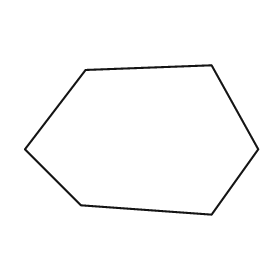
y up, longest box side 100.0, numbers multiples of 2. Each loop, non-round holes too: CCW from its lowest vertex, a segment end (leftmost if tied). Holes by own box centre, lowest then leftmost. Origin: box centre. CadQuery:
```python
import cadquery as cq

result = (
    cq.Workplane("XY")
    .moveTo(30.0, -32.0)
    .lineTo(50.0, -4.0)
    .lineTo(30.0, 32.0)
    .lineTo(-24.0, 30.0)
    .lineTo(-50.0, -4.0)
    .lineTo(-26.0, -28.0)
    .close()
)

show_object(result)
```